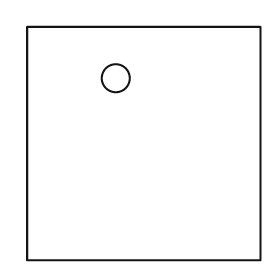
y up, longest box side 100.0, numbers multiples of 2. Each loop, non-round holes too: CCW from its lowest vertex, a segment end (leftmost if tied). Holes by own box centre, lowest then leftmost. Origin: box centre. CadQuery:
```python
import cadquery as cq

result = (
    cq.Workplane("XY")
    .moveTo(-50.0, -50.0)
    .lineTo(50.0, -50.0)
    .lineTo(50.0, 50.0)
    .lineTo(-50.0, 50.0)
    .close()
    .moveTo(-12.0, 28.0)
    .circle(6.0)
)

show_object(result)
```